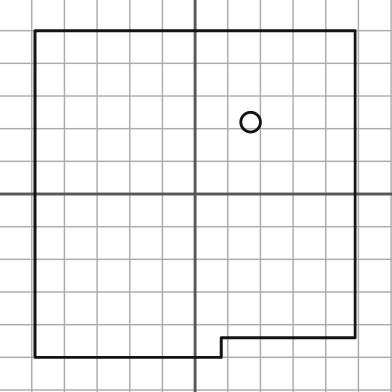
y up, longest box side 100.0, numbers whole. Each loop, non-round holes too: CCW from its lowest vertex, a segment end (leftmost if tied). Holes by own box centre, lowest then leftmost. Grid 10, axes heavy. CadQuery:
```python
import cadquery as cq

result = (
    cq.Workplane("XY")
    .moveTo(-49.0, -50.0)
    .lineTo(8.0, -50.0)
    .lineTo(8.0, -44.0)
    .lineTo(49.0, -44.0)
    .lineTo(49.0, 50.0)
    .lineTo(-49.0, 50.0)
    .close()
    .moveTo(17.0, 22.0)
    .circle(3.0)
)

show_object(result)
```